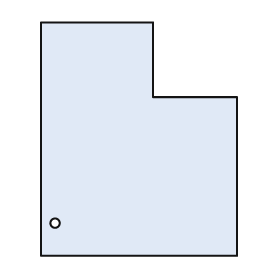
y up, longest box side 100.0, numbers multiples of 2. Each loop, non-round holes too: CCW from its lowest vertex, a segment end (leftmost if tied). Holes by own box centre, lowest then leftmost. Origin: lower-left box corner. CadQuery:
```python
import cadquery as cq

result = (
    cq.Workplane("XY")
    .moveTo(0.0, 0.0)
    .lineTo(84.0, 0.0)
    .lineTo(84.0, 68.0)
    .lineTo(48.0, 68.0)
    .lineTo(48.0, 100.0)
    .lineTo(0.0, 100.0)
    .close()
    .moveTo(6.0, 14.0)
    .circle(2.0)
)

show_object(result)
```